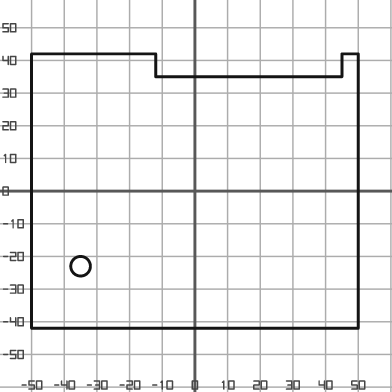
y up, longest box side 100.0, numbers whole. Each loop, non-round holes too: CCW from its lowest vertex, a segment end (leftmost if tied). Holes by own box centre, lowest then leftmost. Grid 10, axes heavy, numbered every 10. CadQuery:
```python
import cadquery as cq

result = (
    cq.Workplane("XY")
    .moveTo(-50.0, -42.0)
    .lineTo(50.0, -42.0)
    .lineTo(50.0, 42.0)
    .lineTo(45.0, 42.0)
    .lineTo(45.0, 35.0)
    .lineTo(-12.0, 35.0)
    .lineTo(-12.0, 42.0)
    .lineTo(-50.0, 42.0)
    .close()
    .moveTo(-35.0, -23.0)
    .circle(3.0)
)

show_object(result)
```